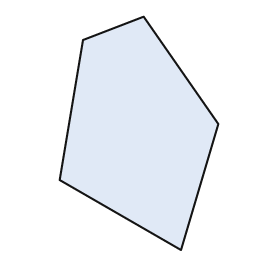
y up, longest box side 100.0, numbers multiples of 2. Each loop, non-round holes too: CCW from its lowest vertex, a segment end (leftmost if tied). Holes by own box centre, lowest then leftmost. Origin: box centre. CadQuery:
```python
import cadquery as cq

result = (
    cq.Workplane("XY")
    .moveTo(18.0, -50.0)
    .lineTo(34.0, 4.0)
    .lineTo(2.0, 50.0)
    .lineTo(-24.0, 40.0)
    .lineTo(-34.0, -20.0)
    .close()
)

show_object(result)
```